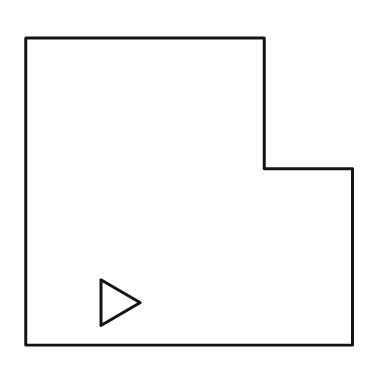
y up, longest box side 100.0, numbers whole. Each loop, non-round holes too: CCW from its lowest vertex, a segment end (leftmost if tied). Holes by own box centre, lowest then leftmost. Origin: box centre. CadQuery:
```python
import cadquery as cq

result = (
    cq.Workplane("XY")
    .moveTo(-50.0, -47.0)
    .lineTo(50.0, -47.0)
    .lineTo(50.0, 7.0)
    .lineTo(23.0, 7.0)
    .lineTo(23.0, 47.0)
    .lineTo(-50.0, 47.0)
    .close()
    .moveTo(-27.0, -41.0)
    .lineTo(-15.0, -34.0)
    .lineTo(-27.0, -27.0)
    .close()
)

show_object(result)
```